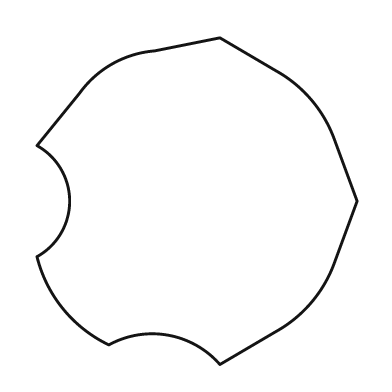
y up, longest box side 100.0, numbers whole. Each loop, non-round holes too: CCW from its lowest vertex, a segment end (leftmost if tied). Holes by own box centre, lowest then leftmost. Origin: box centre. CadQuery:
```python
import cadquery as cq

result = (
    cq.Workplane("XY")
    .moveTo(7.0, -50.0)
    .lineTo(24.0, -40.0)
    .threePointArc((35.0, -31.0), (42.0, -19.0))
    .lineTo(49.0, 0.0)
    .lineTo(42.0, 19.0)
    .threePointArc((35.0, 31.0), (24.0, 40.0))
    .lineTo(7.0, 50.0)
    .lineTo(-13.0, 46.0)
    .threePointArc((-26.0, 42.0), (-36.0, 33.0))
    .lineTo(-49.0, 17.0)
    .threePointArc((-39.0, 0.0), (-49.0, -17.0))
    .threePointArc((-41.0, -33.0), (-27.0, -44.0))
    .threePointArc((-9.0, -41.0), (7.0, -50.0))
    .close()
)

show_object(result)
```